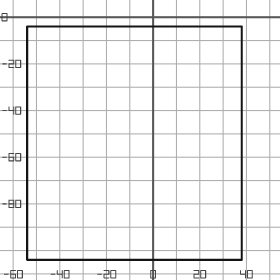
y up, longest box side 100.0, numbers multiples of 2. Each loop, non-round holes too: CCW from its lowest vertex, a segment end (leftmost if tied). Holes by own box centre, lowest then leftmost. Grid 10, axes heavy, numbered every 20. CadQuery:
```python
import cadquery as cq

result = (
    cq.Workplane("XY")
    .moveTo(-54.0, -104.0)
    .lineTo(38.0, -104.0)
    .lineTo(38.0, -4.0)
    .lineTo(-54.0, -4.0)
    .close()
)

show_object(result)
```